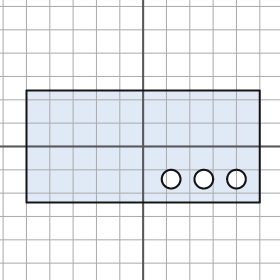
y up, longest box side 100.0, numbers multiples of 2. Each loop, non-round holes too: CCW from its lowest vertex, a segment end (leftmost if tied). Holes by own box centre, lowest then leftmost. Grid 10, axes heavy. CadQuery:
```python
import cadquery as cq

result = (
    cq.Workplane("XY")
    .moveTo(-50.0, -24.0)
    .lineTo(50.0, -24.0)
    .lineTo(50.0, 24.0)
    .lineTo(-50.0, 24.0)
    .close()
    .moveTo(12.0, -14.0)
    .circle(4.0)
    .moveTo(26.0, -14.0)
    .circle(4.0)
    .moveTo(40.0, -14.0)
    .circle(4.0)
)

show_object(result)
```